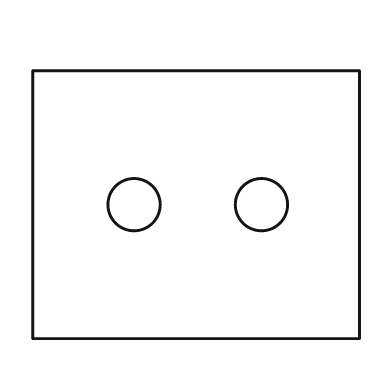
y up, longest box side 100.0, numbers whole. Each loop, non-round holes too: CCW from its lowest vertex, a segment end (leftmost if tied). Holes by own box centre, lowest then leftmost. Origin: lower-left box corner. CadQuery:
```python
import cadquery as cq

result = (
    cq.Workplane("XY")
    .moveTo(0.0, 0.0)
    .lineTo(100.0, 0.0)
    .lineTo(100.0, 82.0)
    .lineTo(0.0, 82.0)
    .close()
    .moveTo(31.0, 41.0)
    .circle(8.0)
    .moveTo(70.0, 41.0)
    .circle(8.0)
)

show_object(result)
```